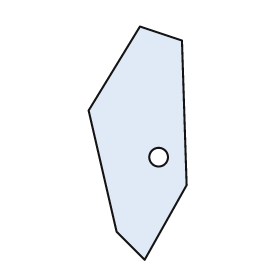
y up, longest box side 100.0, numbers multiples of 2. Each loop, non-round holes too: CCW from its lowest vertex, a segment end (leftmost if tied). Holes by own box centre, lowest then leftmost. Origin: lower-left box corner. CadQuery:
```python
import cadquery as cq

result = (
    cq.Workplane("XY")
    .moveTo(24.0, 0.0)
    .lineTo(42.0, 32.0)
    .lineTo(40.0, 94.0)
    .lineTo(22.0, 100.0)
    .lineTo(0.0, 64.0)
    .lineTo(12.0, 12.0)
    .close()
    .moveTo(30.0, 44.0)
    .circle(4.0)
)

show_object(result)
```